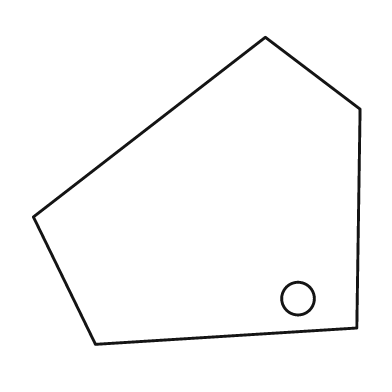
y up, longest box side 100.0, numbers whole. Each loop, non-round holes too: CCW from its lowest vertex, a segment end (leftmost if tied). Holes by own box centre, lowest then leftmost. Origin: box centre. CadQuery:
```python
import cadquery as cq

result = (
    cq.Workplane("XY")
    .moveTo(-31.0, -47.0)
    .lineTo(49.0, -42.0)
    .lineTo(50.0, 25.0)
    .lineTo(21.0, 47.0)
    .lineTo(-50.0, -8.0)
    .close()
    .moveTo(31.0, -33.0)
    .circle(5.0)
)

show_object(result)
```